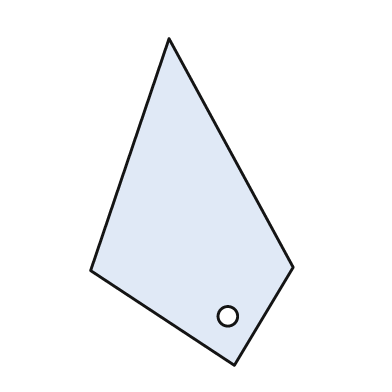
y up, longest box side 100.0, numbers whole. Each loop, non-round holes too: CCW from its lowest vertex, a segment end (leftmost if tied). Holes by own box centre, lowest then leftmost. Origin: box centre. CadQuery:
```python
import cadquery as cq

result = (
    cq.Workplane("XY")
    .moveTo(13.0, -50.0)
    .lineTo(31.0, -20.0)
    .lineTo(-7.0, 50.0)
    .lineTo(-31.0, -21.0)
    .close()
    .moveTo(11.0, -35.0)
    .circle(3.0)
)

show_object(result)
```